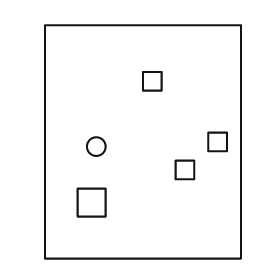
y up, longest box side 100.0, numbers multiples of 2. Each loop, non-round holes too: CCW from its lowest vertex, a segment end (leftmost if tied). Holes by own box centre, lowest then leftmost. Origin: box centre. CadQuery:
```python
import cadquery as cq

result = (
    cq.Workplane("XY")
    .moveTo(-42.0, -50.0)
    .lineTo(42.0, -50.0)
    .lineTo(42.0, 50.0)
    .lineTo(-42.0, 50.0)
    .close()
    .moveTo(-28.0, -32.0)
    .lineTo(-16.0, -32.0)
    .lineTo(-16.0, -20.0)
    .lineTo(-28.0, -20.0)
    .close()
    .moveTo(14.0, -16.0)
    .lineTo(22.0, -16.0)
    .lineTo(22.0, -8.0)
    .lineTo(14.0, -8.0)
    .close()
    .moveTo(-20.0, -2.0)
    .circle(4.0)
    .moveTo(28.0, -4.0)
    .lineTo(36.0, -4.0)
    .lineTo(36.0, 4.0)
    .lineTo(28.0, 4.0)
    .close()
    .moveTo(0.0, 22.0)
    .lineTo(8.0, 22.0)
    .lineTo(8.0, 30.0)
    .lineTo(0.0, 30.0)
    .close()
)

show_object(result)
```